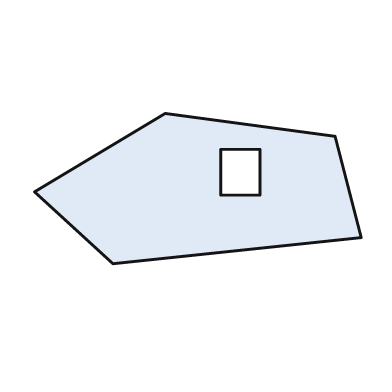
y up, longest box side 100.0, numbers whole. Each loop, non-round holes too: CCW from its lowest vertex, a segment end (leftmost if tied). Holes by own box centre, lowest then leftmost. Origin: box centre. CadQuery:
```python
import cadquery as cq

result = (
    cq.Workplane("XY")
    .moveTo(-26.0, -23.0)
    .lineTo(50.0, -15.0)
    .lineTo(42.0, 16.0)
    .lineTo(-10.0, 23.0)
    .lineTo(-50.0, -1.0)
    .close()
    .moveTo(7.0, -2.0)
    .lineTo(19.0, -2.0)
    .lineTo(19.0, 12.0)
    .lineTo(7.0, 12.0)
    .close()
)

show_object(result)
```